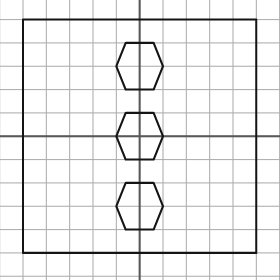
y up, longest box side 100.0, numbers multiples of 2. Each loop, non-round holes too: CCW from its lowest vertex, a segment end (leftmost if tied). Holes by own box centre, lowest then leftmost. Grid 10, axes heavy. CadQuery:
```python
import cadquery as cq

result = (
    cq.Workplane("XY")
    .moveTo(-50.0, -50.0)
    .lineTo(50.0, -50.0)
    .lineTo(50.0, 50.0)
    .lineTo(-50.0, 50.0)
    .close()
    .moveTo(-6.0, -40.0)
    .lineTo(6.0, -40.0)
    .lineTo(10.0, -30.0)
    .lineTo(6.0, -20.0)
    .lineTo(-6.0, -20.0)
    .lineTo(-10.0, -30.0)
    .close()
    .moveTo(-6.0, -10.0)
    .lineTo(6.0, -10.0)
    .lineTo(10.0, 0.0)
    .lineTo(6.0, 10.0)
    .lineTo(-6.0, 10.0)
    .lineTo(-10.0, 0.0)
    .close()
    .moveTo(-6.0, 20.0)
    .lineTo(6.0, 20.0)
    .lineTo(10.0, 30.0)
    .lineTo(6.0, 40.0)
    .lineTo(-6.0, 40.0)
    .lineTo(-10.0, 30.0)
    .close()
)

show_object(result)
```